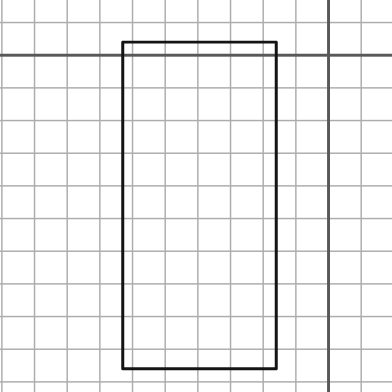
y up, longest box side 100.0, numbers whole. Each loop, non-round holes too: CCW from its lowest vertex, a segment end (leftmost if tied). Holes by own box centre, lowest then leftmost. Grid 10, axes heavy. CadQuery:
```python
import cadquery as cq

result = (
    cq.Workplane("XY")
    .moveTo(-63.0, -96.0)
    .lineTo(-16.0, -96.0)
    .lineTo(-16.0, 4.0)
    .lineTo(-63.0, 4.0)
    .close()
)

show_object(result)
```